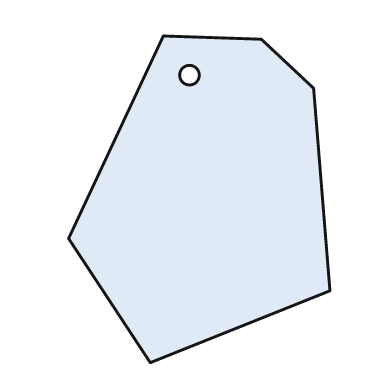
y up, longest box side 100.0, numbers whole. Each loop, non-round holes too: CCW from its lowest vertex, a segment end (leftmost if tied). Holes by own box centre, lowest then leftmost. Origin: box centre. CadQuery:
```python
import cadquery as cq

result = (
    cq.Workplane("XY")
    .moveTo(-15.0, -50.0)
    .lineTo(40.0, -28.0)
    .lineTo(35.0, 34.0)
    .lineTo(19.0, 49.0)
    .lineTo(-11.0, 50.0)
    .lineTo(-40.0, -12.0)
    .close()
    .moveTo(-3.0, 38.0)
    .circle(3.0)
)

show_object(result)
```